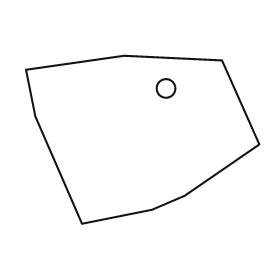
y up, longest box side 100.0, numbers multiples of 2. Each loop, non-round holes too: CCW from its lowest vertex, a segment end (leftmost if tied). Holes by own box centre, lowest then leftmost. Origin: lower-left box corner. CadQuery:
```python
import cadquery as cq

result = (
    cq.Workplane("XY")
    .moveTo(24.0, 0.0)
    .lineTo(54.0, 6.0)
    .lineTo(68.0, 12.0)
    .lineTo(100.0, 34.0)
    .lineTo(84.0, 70.0)
    .lineTo(42.0, 72.0)
    .lineTo(0.0, 66.0)
    .lineTo(4.0, 46.0)
    .close()
    .moveTo(60.0, 58.0)
    .circle(4.0)
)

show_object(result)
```